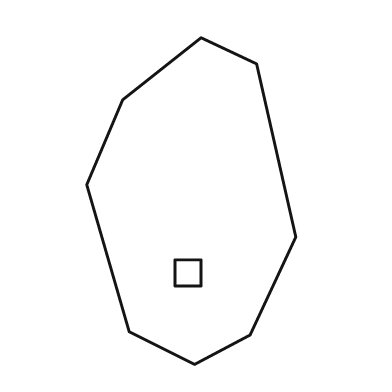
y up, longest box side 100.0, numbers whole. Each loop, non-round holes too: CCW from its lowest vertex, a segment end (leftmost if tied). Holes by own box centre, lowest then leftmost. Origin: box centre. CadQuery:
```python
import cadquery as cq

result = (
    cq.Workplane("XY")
    .moveTo(1.0, -50.0)
    .lineTo(18.0, -41.0)
    .lineTo(32.0, -11.0)
    .lineTo(20.0, 42.0)
    .lineTo(3.0, 50.0)
    .lineTo(-21.0, 31.0)
    .lineTo(-32.0, 5.0)
    .lineTo(-19.0, -40.0)
    .close()
    .moveTo(-5.0, -26.0)
    .lineTo(3.0, -26.0)
    .lineTo(3.0, -18.0)
    .lineTo(-5.0, -18.0)
    .close()
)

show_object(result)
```